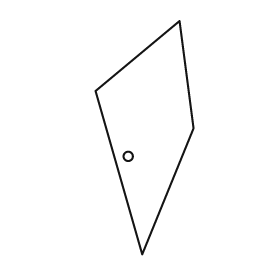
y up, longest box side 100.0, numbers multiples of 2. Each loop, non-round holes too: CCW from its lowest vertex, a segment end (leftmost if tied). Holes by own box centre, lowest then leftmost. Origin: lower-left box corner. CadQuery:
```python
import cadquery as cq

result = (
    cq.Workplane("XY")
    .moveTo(20.0, 0.0)
    .lineTo(42.0, 54.0)
    .lineTo(36.0, 100.0)
    .lineTo(0.0, 70.0)
    .close()
    .moveTo(14.0, 42.0)
    .circle(2.0)
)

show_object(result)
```